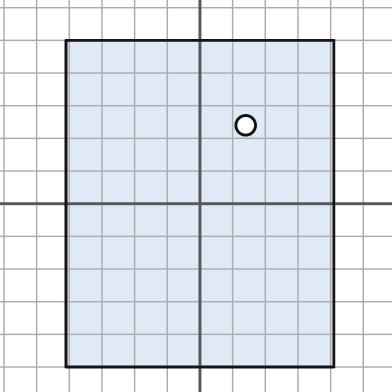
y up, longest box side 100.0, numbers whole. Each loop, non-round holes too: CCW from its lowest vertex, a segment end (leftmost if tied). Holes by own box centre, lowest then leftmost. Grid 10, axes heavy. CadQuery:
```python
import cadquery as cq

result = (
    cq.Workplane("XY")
    .moveTo(-41.0, -50.0)
    .lineTo(41.0, -50.0)
    .lineTo(41.0, 50.0)
    .lineTo(-41.0, 50.0)
    .close()
    .moveTo(14.0, 24.0)
    .circle(3.0)
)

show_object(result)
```